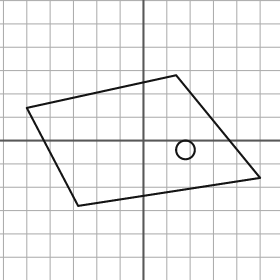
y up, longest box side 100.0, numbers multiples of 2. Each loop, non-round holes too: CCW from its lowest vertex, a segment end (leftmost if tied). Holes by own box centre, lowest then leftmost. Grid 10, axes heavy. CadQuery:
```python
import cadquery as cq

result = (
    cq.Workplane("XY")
    .moveTo(-28.0, -28.0)
    .lineTo(50.0, -16.0)
    .lineTo(14.0, 28.0)
    .lineTo(-50.0, 14.0)
    .close()
    .moveTo(18.0, -4.0)
    .circle(4.0)
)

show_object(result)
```